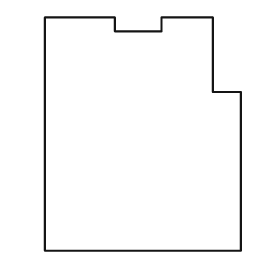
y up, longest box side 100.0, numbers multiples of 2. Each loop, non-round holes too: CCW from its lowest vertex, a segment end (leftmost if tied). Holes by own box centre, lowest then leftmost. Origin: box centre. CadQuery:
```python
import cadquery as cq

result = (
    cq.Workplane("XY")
    .moveTo(-42.0, -50.0)
    .lineTo(42.0, -50.0)
    .lineTo(42.0, 18.0)
    .lineTo(30.0, 18.0)
    .lineTo(30.0, 50.0)
    .lineTo(8.0, 50.0)
    .lineTo(8.0, 44.0)
    .lineTo(-12.0, 44.0)
    .lineTo(-12.0, 50.0)
    .lineTo(-42.0, 50.0)
    .close()
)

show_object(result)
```